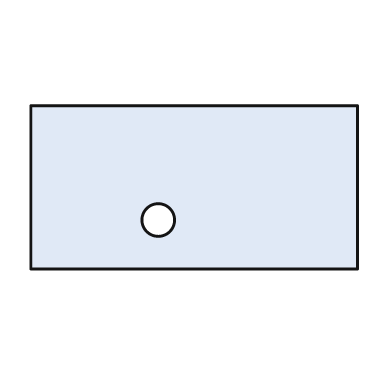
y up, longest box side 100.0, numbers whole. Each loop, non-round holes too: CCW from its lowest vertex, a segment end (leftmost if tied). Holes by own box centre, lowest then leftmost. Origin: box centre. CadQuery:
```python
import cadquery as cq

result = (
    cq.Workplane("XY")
    .moveTo(-50.0, -25.0)
    .lineTo(50.0, -25.0)
    .lineTo(50.0, 25.0)
    .lineTo(-50.0, 25.0)
    .close()
    .moveTo(-11.0, -10.0)
    .circle(5.0)
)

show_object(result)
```